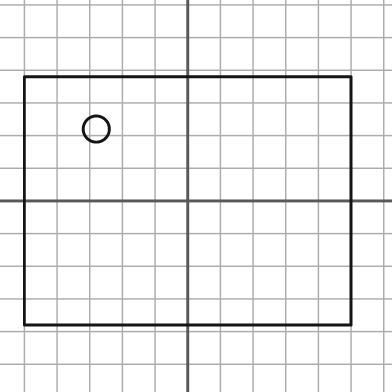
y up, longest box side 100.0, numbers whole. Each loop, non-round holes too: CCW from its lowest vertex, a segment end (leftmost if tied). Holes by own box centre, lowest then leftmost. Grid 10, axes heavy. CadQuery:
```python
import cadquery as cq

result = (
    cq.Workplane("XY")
    .moveTo(-50.0, -38.0)
    .lineTo(50.0, -38.0)
    .lineTo(50.0, 38.0)
    .lineTo(-50.0, 38.0)
    .close()
    .moveTo(-28.0, 22.0)
    .circle(4.0)
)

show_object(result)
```